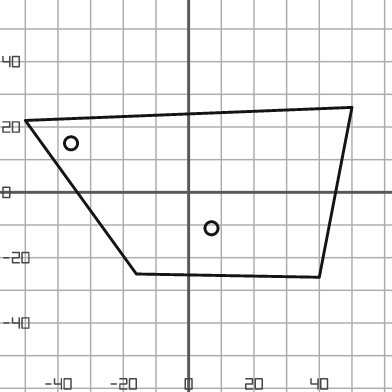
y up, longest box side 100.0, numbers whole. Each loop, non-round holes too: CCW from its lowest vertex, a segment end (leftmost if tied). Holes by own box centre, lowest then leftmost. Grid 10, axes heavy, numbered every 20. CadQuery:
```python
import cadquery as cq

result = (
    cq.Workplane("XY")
    .moveTo(40.0, -26.0)
    .lineTo(50.0, 26.0)
    .lineTo(-50.0, 22.0)
    .lineTo(-16.0, -25.0)
    .close()
    .moveTo(7.0, -11.0)
    .circle(2.0)
    .moveTo(-36.0, 15.0)
    .circle(2.0)
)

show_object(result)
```